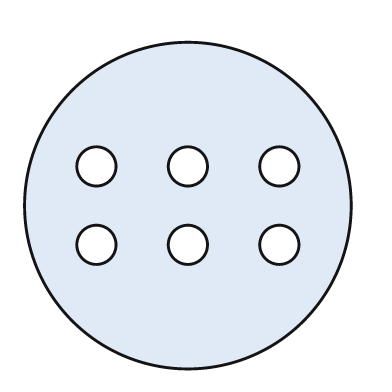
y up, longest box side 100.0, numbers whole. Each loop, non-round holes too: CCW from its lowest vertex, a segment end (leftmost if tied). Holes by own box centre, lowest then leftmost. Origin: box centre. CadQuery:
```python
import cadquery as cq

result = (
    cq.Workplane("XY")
    .moveTo(0.0, 0.0)
    .circle(50.0)
    .moveTo(-28.0, -12.0)
    .circle(6.0)
    .moveTo(0.0, -12.0)
    .circle(6.0)
    .moveTo(28.0, -12.0)
    .circle(6.0)
    .moveTo(-28.0, 12.0)
    .circle(6.0)
    .moveTo(0.0, 12.0)
    .circle(6.0)
    .moveTo(28.0, 12.0)
    .circle(6.0)
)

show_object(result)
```